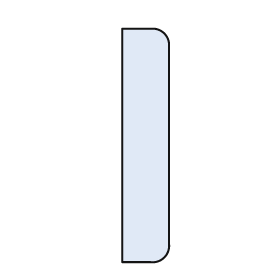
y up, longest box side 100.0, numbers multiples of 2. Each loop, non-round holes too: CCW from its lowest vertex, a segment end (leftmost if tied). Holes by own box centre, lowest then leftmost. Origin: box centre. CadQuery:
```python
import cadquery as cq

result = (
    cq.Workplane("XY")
    .moveTo(-10.0, -50.0)
    .lineTo(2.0, -50.0)
    .threePointArc((8.0, -48.0), (10.0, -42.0))
    .lineTo(10.0, 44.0)
    .threePointArc((8.0, 48.0), (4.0, 50.0))
    .lineTo(-10.0, 50.0)
    .close()
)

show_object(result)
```